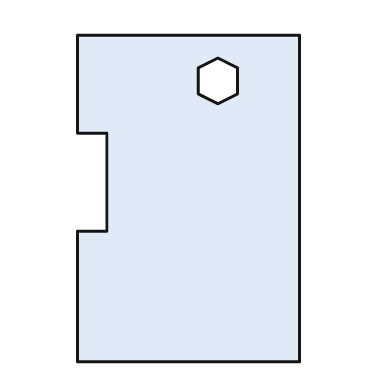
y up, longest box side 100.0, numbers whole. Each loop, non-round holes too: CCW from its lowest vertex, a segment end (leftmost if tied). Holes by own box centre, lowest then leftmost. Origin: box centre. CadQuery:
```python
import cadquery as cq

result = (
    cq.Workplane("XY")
    .moveTo(-34.0, -50.0)
    .lineTo(34.0, -50.0)
    .lineTo(34.0, 50.0)
    .lineTo(-34.0, 50.0)
    .lineTo(-34.0, 20.0)
    .lineTo(-25.0, 20.0)
    .lineTo(-25.0, -10.0)
    .lineTo(-34.0, -10.0)
    .close()
    .moveTo(9.0, 29.0)
    .lineTo(15.0, 32.0)
    .lineTo(15.0, 40.0)
    .lineTo(9.0, 43.0)
    .lineTo(3.0, 40.0)
    .lineTo(3.0, 32.0)
    .close()
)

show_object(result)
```